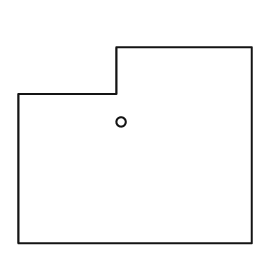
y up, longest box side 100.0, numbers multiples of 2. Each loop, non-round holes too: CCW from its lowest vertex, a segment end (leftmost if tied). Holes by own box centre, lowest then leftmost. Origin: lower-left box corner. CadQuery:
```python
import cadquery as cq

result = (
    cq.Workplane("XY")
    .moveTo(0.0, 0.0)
    .lineTo(100.0, 0.0)
    .lineTo(100.0, 84.0)
    .lineTo(42.0, 84.0)
    .lineTo(42.0, 64.0)
    .lineTo(0.0, 64.0)
    .close()
    .moveTo(44.0, 52.0)
    .circle(2.0)
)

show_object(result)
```